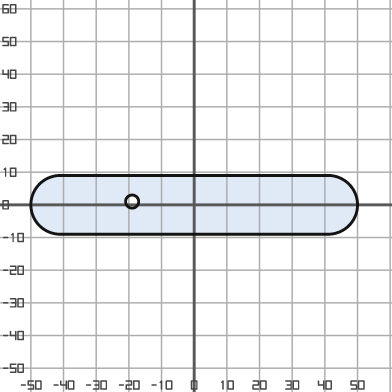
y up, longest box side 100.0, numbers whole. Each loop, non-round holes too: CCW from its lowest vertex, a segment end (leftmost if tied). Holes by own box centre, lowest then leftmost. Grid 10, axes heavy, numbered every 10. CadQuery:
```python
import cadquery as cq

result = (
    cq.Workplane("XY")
    .moveTo(-41.0, -9.0)
    .lineTo(41.0, -9.0)
    .threePointArc((50.0, 0.0), (41.0, 9.0))
    .lineTo(-41.0, 9.0)
    .threePointArc((-50.0, 0.0), (-41.0, -9.0))
    .close()
    .moveTo(-19.0, 1.0)
    .circle(2.0)
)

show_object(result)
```